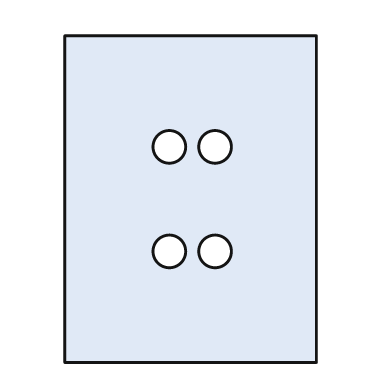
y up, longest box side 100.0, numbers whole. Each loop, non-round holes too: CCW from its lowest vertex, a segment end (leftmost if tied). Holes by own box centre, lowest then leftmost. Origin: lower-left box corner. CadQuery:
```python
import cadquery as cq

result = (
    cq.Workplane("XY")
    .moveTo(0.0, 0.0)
    .lineTo(77.0, 0.0)
    .lineTo(77.0, 100.0)
    .lineTo(0.0, 100.0)
    .close()
    .moveTo(32.0, 34.0)
    .circle(5.0)
    .moveTo(46.0, 34.0)
    .circle(5.0)
    .moveTo(32.0, 66.0)
    .circle(5.0)
    .moveTo(46.0, 66.0)
    .circle(5.0)
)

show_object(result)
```